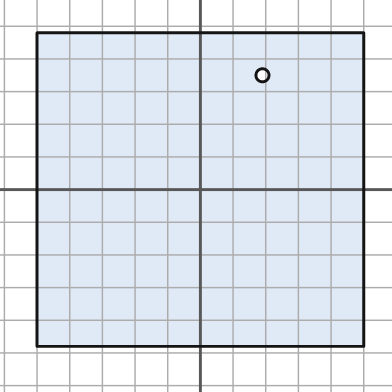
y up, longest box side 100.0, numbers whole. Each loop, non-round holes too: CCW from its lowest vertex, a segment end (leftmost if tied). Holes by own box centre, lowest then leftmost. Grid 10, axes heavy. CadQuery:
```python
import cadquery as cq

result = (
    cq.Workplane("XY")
    .moveTo(-50.0, -48.0)
    .lineTo(50.0, -48.0)
    .lineTo(50.0, 48.0)
    .lineTo(-50.0, 48.0)
    .close()
    .moveTo(19.0, 35.0)
    .circle(2.0)
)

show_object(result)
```